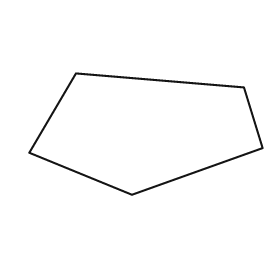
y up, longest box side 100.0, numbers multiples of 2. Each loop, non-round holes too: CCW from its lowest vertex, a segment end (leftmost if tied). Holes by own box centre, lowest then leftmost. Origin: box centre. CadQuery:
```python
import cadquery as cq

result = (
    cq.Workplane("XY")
    .moveTo(-6.0, -26.0)
    .lineTo(50.0, -6.0)
    .lineTo(42.0, 20.0)
    .lineTo(-30.0, 26.0)
    .lineTo(-50.0, -8.0)
    .close()
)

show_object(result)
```